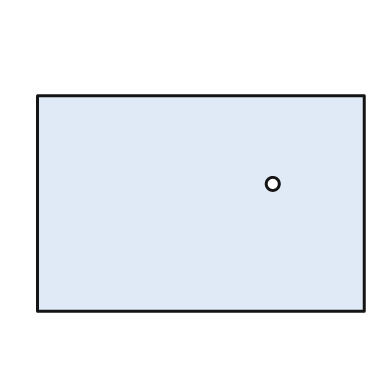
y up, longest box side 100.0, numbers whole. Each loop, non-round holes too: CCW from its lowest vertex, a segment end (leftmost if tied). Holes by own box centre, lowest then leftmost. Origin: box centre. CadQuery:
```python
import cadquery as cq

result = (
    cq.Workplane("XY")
    .moveTo(-50.0, -33.0)
    .lineTo(50.0, -33.0)
    .lineTo(50.0, 33.0)
    .lineTo(-50.0, 33.0)
    .close()
    .moveTo(22.0, 6.0)
    .circle(2.0)
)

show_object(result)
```